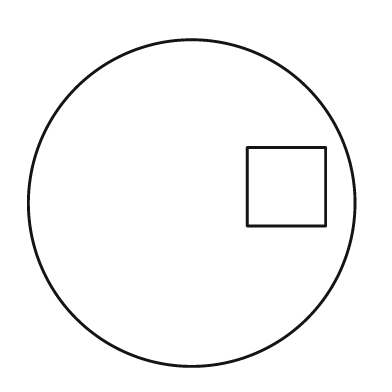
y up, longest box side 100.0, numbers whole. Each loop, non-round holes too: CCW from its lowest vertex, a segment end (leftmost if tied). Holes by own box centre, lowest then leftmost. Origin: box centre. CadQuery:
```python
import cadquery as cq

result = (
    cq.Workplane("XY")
    .moveTo(0.0, 0.0)
    .circle(50.0)
    .moveTo(17.0, -7.0)
    .lineTo(41.0, -7.0)
    .lineTo(41.0, 17.0)
    .lineTo(17.0, 17.0)
    .close()
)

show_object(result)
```